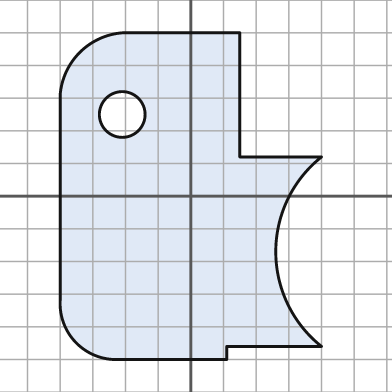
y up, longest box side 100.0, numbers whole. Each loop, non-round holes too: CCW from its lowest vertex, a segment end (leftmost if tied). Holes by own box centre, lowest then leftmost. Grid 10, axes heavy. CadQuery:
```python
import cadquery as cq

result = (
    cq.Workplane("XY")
    .moveTo(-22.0, -50.0)
    .lineTo(11.0, -50.0)
    .lineTo(11.0, -46.0)
    .lineTo(40.0, -46.0)
    .threePointArc((26.0, -17.0), (40.0, 12.0))
    .lineTo(15.0, 12.0)
    .lineTo(15.0, 50.0)
    .lineTo(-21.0, 50.0)
    .threePointArc((-34.0, 44.0), (-40.0, 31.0))
    .lineTo(-40.0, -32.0)
    .threePointArc((-35.0, -45.0), (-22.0, -50.0))
    .close()
    .moveTo(-21.0, 25.0)
    .circle(7.0)
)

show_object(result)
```